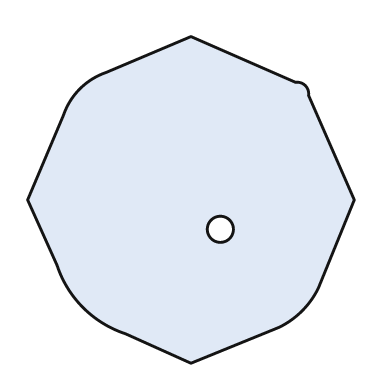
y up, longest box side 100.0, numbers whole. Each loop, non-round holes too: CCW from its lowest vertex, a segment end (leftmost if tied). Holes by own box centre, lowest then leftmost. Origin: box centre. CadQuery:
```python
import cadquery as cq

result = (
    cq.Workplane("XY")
    .moveTo(0.0, -50.0)
    .lineTo(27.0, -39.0)
    .threePointArc((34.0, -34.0), (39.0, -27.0))
    .lineTo(50.0, 0.0)
    .lineTo(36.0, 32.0)
    .threePointArc((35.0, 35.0), (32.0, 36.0))
    .lineTo(0.0, 50.0)
    .lineTo(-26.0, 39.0)
    .threePointArc((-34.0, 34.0), (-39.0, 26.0))
    .lineTo(-50.0, 0.0)
    .lineTo(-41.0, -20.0)
    .threePointArc((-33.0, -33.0), (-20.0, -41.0))
    .close()
    .moveTo(9.0, -9.0)
    .circle(4.0)
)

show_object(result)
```